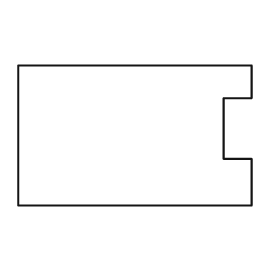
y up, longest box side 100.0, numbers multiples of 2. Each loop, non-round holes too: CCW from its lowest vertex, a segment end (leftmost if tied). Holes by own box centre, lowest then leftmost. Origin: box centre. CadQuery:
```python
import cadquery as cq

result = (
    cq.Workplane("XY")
    .moveTo(-50.0, -30.0)
    .lineTo(50.0, -30.0)
    .lineTo(50.0, -10.0)
    .lineTo(38.0, -10.0)
    .lineTo(38.0, 16.0)
    .lineTo(50.0, 16.0)
    .lineTo(50.0, 30.0)
    .lineTo(-50.0, 30.0)
    .close()
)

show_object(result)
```